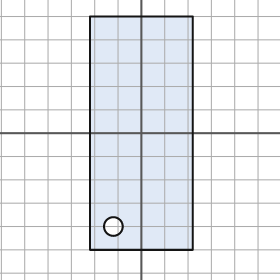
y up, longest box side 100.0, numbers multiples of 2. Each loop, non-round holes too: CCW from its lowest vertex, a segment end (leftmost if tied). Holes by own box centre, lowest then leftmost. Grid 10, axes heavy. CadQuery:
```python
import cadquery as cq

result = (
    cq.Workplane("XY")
    .moveTo(-22.0, -50.0)
    .lineTo(22.0, -50.0)
    .lineTo(22.0, 50.0)
    .lineTo(-22.0, 50.0)
    .close()
    .moveTo(-12.0, -40.0)
    .circle(4.0)
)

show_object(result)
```